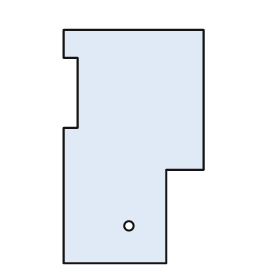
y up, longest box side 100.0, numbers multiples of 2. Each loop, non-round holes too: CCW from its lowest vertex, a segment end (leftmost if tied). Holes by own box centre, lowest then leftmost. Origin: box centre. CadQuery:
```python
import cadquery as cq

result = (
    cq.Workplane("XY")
    .moveTo(-30.0, -50.0)
    .lineTo(14.0, -50.0)
    .lineTo(14.0, -10.0)
    .lineTo(30.0, -10.0)
    .lineTo(30.0, 50.0)
    .lineTo(-30.0, 50.0)
    .lineTo(-30.0, 38.0)
    .lineTo(-24.0, 38.0)
    .lineTo(-24.0, 8.0)
    .lineTo(-30.0, 8.0)
    .close()
    .moveTo(-2.0, -34.0)
    .circle(2.0)
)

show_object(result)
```